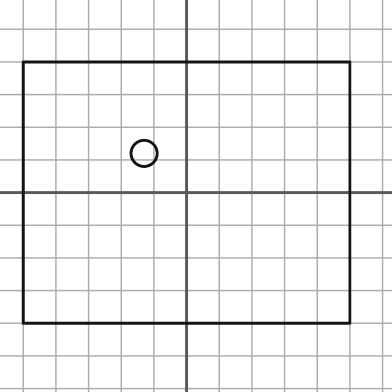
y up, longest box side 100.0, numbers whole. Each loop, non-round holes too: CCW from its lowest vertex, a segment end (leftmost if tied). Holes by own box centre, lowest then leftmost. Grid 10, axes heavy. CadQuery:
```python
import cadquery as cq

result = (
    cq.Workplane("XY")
    .moveTo(-50.0, -40.0)
    .lineTo(50.0, -40.0)
    .lineTo(50.0, 40.0)
    .lineTo(-50.0, 40.0)
    .close()
    .moveTo(-13.0, 12.0)
    .circle(4.0)
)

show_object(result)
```